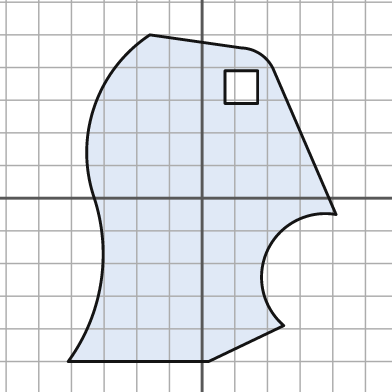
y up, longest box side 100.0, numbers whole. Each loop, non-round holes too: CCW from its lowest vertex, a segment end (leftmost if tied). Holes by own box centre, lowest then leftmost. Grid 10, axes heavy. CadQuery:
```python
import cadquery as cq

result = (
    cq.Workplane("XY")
    .moveTo(-41.0, -50.0)
    .lineTo(2.0, -50.0)
    .lineTo(25.0, -39.0)
    .threePointArc((20.0, -16.0), (41.0, -5.0))
    .lineTo(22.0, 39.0)
    .threePointArc((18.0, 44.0), (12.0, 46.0))
    .lineTo(-16.0, 50.0)
    .threePointArc((-33.0, 28.0), (-33.0, 0.0))
    .threePointArc((-31.0, -26.0), (-41.0, -50.0))
    .close()
    .moveTo(7.0, 29.0)
    .lineTo(17.0, 29.0)
    .lineTo(17.0, 39.0)
    .lineTo(7.0, 39.0)
    .close()
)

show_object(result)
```